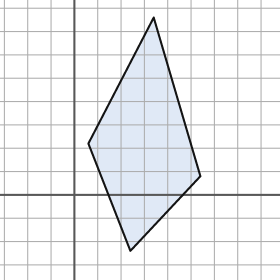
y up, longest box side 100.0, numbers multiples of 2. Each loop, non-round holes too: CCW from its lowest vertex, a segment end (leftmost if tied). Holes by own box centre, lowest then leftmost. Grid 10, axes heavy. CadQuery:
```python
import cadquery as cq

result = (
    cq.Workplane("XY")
    .moveTo(24.0, -24.0)
    .lineTo(54.0, 8.0)
    .lineTo(34.0, 76.0)
    .lineTo(6.0, 22.0)
    .close()
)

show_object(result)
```